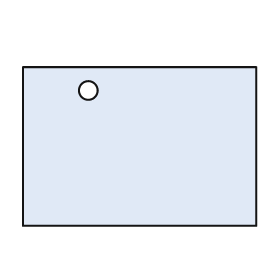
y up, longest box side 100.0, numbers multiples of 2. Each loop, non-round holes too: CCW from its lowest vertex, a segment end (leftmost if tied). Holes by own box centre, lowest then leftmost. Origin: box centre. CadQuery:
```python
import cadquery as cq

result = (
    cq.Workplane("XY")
    .moveTo(-50.0, -34.0)
    .lineTo(50.0, -34.0)
    .lineTo(50.0, 34.0)
    .lineTo(-50.0, 34.0)
    .close()
    .moveTo(-22.0, 24.0)
    .circle(4.0)
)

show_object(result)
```